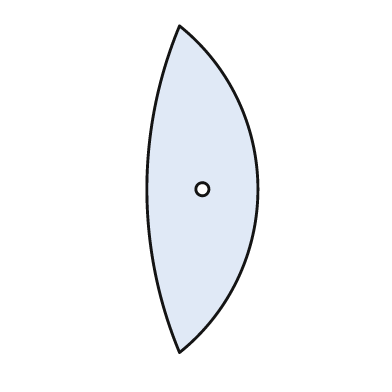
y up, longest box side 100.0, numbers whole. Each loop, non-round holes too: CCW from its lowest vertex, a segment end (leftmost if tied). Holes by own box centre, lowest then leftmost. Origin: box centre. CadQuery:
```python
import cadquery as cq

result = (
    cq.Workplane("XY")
    .moveTo(-7.0, -50.0)
    .threePointArc((17.0, 0.0), (-7.0, 50.0))
    .threePointArc((-17.0, 0.0), (-7.0, -50.0))
    .close()
    .moveTo(0.0, 0.0)
    .circle(2.0)
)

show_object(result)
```